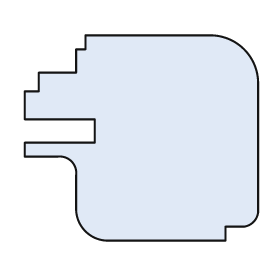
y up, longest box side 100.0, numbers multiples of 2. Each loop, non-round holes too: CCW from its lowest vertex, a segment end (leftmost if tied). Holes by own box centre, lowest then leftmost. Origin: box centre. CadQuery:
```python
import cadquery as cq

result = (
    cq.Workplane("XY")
    .moveTo(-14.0, -44.0)
    .lineTo(36.0, -44.0)
    .lineTo(36.0, -38.0)
    .lineTo(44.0, -38.0)
    .threePointArc((48.0, -36.0), (50.0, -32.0))
    .lineTo(50.0, 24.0)
    .threePointArc((44.0, 38.0), (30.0, 44.0))
    .lineTo(-24.0, 44.0)
    .lineTo(-24.0, 38.0)
    .lineTo(-28.0, 38.0)
    .lineTo(-28.0, 28.0)
    .lineTo(-44.0, 28.0)
    .lineTo(-44.0, 20.0)
    .lineTo(-50.0, 20.0)
    .lineTo(-50.0, 8.0)
    .lineTo(-20.0, 8.0)
    .lineTo(-20.0, -2.0)
    .lineTo(-50.0, -2.0)
    .lineTo(-50.0, -8.0)
    .lineTo(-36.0, -8.0)
    .threePointArc((-30.0, -10.0), (-28.0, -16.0))
    .lineTo(-28.0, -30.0)
    .threePointArc((-24.0, -40.0), (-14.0, -44.0))
    .close()
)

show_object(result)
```